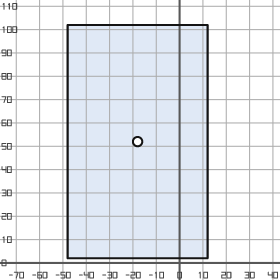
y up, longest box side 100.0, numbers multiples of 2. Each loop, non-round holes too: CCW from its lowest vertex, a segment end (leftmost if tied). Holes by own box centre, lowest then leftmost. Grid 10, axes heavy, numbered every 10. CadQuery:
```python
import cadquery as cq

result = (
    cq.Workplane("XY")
    .moveTo(-48.0, 2.0)
    .lineTo(12.0, 2.0)
    .lineTo(12.0, 102.0)
    .lineTo(-48.0, 102.0)
    .close()
    .moveTo(-18.0, 52.0)
    .circle(2.0)
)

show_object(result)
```